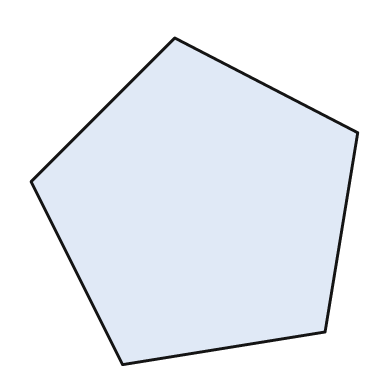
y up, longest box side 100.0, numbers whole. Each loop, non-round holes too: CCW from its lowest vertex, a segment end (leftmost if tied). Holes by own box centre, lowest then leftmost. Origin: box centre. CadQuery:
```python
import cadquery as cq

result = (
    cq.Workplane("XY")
    .moveTo(-22.0, -50.0)
    .lineTo(40.0, -40.0)
    .lineTo(50.0, 21.0)
    .lineTo(-6.0, 50.0)
    .lineTo(-50.0, 6.0)
    .close()
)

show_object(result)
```